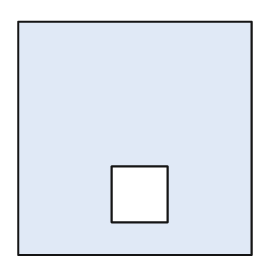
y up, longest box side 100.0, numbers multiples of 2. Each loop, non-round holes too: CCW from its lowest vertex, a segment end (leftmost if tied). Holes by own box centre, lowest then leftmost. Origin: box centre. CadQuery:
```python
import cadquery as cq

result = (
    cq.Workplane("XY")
    .moveTo(-50.0, -50.0)
    .lineTo(50.0, -50.0)
    .lineTo(50.0, 50.0)
    .lineTo(-50.0, 50.0)
    .close()
    .moveTo(-10.0, -36.0)
    .lineTo(14.0, -36.0)
    .lineTo(14.0, -12.0)
    .lineTo(-10.0, -12.0)
    .close()
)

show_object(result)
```